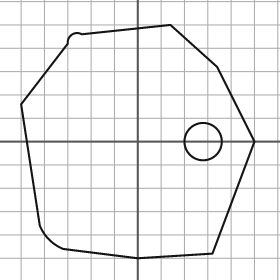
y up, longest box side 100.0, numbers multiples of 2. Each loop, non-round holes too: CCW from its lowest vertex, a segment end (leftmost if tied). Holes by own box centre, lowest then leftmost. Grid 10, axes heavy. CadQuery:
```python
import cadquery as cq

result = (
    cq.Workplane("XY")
    .moveTo(0.0, -50.0)
    .lineTo(32.0, -48.0)
    .lineTo(50.0, 0.0)
    .lineTo(34.0, 32.0)
    .lineTo(14.0, 50.0)
    .lineTo(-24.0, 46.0)
    .threePointArc((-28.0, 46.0), (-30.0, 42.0))
    .lineTo(-50.0, 16.0)
    .lineTo(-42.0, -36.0)
    .threePointArc((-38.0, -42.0), (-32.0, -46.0))
    .close()
    .moveTo(28.0, 0.0)
    .circle(8.0)
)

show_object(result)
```